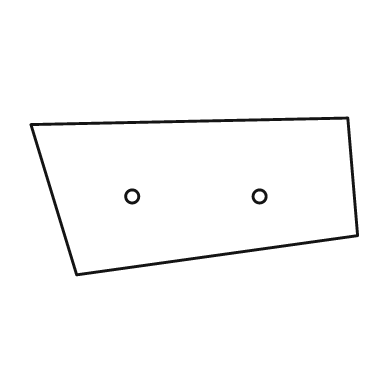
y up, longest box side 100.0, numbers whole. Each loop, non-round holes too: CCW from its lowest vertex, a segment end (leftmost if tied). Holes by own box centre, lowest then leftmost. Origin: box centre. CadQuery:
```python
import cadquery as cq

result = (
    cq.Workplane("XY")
    .moveTo(-36.0, -24.0)
    .lineTo(50.0, -12.0)
    .lineTo(47.0, 24.0)
    .lineTo(-50.0, 22.0)
    .close()
    .moveTo(-19.0, 0.0)
    .circle(2.0)
    .moveTo(20.0, 0.0)
    .circle(2.0)
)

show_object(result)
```